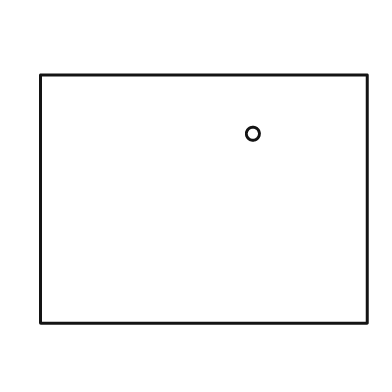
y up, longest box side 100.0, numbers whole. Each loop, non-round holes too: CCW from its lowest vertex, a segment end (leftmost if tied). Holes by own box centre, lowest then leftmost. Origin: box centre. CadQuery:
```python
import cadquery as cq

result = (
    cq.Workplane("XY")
    .moveTo(-50.0, -38.0)
    .lineTo(50.0, -38.0)
    .lineTo(50.0, 38.0)
    .lineTo(-50.0, 38.0)
    .close()
    .moveTo(15.0, 20.0)
    .circle(2.0)
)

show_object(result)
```